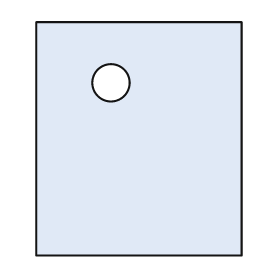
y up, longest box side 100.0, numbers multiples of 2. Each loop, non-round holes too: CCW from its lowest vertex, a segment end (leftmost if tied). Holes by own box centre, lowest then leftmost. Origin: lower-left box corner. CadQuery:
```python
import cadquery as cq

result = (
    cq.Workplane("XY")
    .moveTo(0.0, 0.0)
    .lineTo(88.0, 0.0)
    .lineTo(88.0, 100.0)
    .lineTo(0.0, 100.0)
    .close()
    .moveTo(32.0, 74.0)
    .circle(8.0)
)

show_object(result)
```